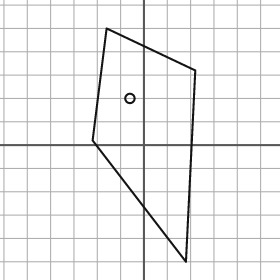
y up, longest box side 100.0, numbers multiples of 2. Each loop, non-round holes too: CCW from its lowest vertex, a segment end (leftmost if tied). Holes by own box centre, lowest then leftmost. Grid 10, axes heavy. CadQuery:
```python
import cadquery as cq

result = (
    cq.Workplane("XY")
    .moveTo(18.0, -50.0)
    .lineTo(22.0, 32.0)
    .lineTo(-16.0, 50.0)
    .lineTo(-22.0, 2.0)
    .close()
    .moveTo(-6.0, 20.0)
    .circle(2.0)
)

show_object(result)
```